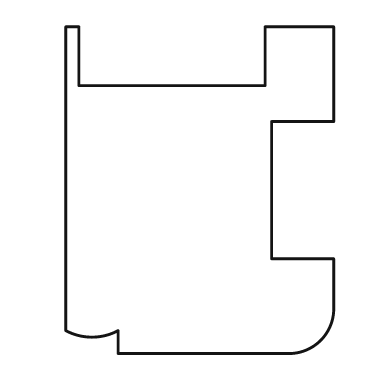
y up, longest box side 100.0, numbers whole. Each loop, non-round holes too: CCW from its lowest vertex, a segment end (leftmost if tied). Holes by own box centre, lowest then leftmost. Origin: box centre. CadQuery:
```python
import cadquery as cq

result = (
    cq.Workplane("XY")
    .moveTo(-25.0, -50.0)
    .lineTo(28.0, -50.0)
    .threePointArc((37.0, -46.0), (41.0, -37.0))
    .lineTo(41.0, -21.0)
    .lineTo(22.0, -21.0)
    .lineTo(22.0, 21.0)
    .lineTo(41.0, 21.0)
    .lineTo(41.0, 50.0)
    .lineTo(20.0, 50.0)
    .lineTo(20.0, 32.0)
    .lineTo(-37.0, 32.0)
    .lineTo(-37.0, 50.0)
    .lineTo(-41.0, 50.0)
    .lineTo(-41.0, -43.0)
    .threePointArc((-33.0, -45.0), (-25.0, -43.0))
    .close()
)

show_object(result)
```